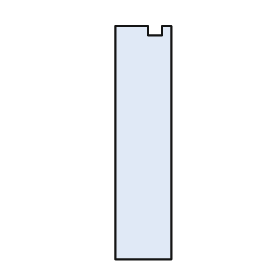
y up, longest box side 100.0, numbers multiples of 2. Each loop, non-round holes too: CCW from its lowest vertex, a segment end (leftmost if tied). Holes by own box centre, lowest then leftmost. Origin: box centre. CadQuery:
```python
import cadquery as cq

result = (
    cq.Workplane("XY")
    .moveTo(-12.0, -50.0)
    .lineTo(12.0, -50.0)
    .lineTo(12.0, 50.0)
    .lineTo(8.0, 50.0)
    .lineTo(8.0, 46.0)
    .lineTo(2.0, 46.0)
    .lineTo(2.0, 50.0)
    .lineTo(-12.0, 50.0)
    .close()
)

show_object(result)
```